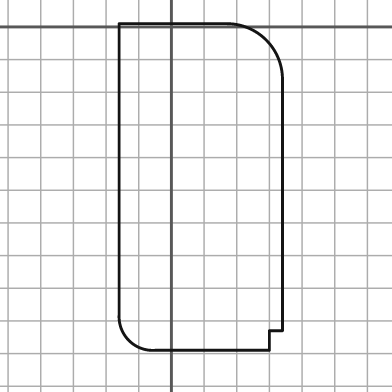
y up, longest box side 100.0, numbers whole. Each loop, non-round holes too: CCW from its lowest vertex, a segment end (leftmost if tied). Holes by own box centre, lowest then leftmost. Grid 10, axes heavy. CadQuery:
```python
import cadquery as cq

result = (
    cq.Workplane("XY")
    .moveTo(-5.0, -99.0)
    .lineTo(30.0, -99.0)
    .lineTo(30.0, -93.0)
    .lineTo(34.0, -93.0)
    .lineTo(34.0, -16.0)
    .threePointArc((29.0, -4.0), (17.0, 1.0))
    .lineTo(-16.0, 1.0)
    .lineTo(-16.0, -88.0)
    .threePointArc((-13.0, -96.0), (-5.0, -99.0))
    .close()
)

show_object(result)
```